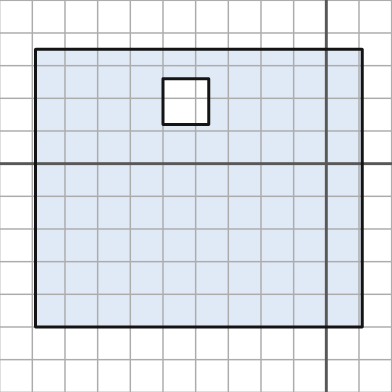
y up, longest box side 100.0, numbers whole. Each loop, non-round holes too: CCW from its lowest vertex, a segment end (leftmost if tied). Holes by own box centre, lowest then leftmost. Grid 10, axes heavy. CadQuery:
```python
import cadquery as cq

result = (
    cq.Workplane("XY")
    .moveTo(-89.0, -50.0)
    .lineTo(11.0, -50.0)
    .lineTo(11.0, 35.0)
    .lineTo(-89.0, 35.0)
    .close()
    .moveTo(-50.0, 12.0)
    .lineTo(-36.0, 12.0)
    .lineTo(-36.0, 26.0)
    .lineTo(-50.0, 26.0)
    .close()
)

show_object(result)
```